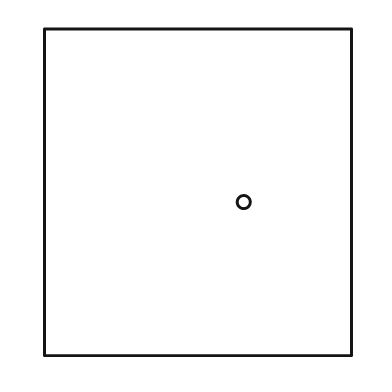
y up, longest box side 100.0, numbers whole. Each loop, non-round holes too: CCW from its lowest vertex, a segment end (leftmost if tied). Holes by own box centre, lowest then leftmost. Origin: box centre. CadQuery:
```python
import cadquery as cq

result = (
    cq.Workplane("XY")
    .moveTo(-47.0, -50.0)
    .lineTo(47.0, -50.0)
    .lineTo(47.0, 50.0)
    .lineTo(-47.0, 50.0)
    .close()
    .moveTo(14.0, -3.0)
    .circle(2.0)
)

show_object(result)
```